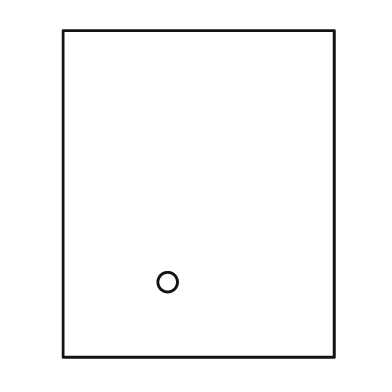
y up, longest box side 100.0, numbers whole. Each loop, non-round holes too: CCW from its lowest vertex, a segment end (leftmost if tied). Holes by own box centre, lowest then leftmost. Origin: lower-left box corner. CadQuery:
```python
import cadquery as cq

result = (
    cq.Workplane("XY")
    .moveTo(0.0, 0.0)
    .lineTo(83.0, 0.0)
    .lineTo(83.0, 100.0)
    .lineTo(0.0, 100.0)
    .close()
    .moveTo(32.0, 23.0)
    .circle(3.0)
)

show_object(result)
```